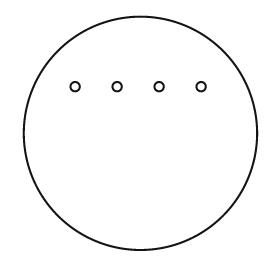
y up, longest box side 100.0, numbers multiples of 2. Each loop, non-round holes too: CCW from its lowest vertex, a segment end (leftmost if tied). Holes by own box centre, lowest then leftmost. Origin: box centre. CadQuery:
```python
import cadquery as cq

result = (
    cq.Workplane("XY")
    .moveTo(0.0, 0.0)
    .circle(50.0)
    .moveTo(-28.0, 20.0)
    .circle(2.0)
    .moveTo(-10.0, 20.0)
    .circle(2.0)
    .moveTo(8.0, 20.0)
    .circle(2.0)
    .moveTo(26.0, 20.0)
    .circle(2.0)
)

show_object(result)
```